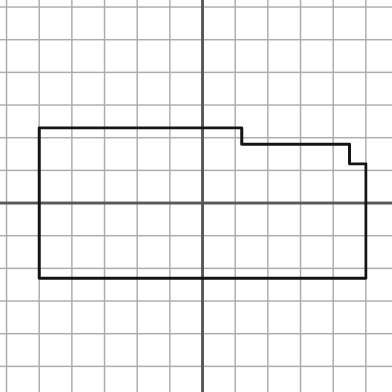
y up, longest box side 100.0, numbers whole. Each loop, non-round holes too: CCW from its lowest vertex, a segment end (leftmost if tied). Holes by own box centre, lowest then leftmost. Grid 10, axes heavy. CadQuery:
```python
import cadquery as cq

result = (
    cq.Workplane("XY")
    .moveTo(-50.0, -23.0)
    .lineTo(50.0, -23.0)
    .lineTo(50.0, 12.0)
    .lineTo(45.0, 12.0)
    .lineTo(45.0, 18.0)
    .lineTo(12.0, 18.0)
    .lineTo(12.0, 23.0)
    .lineTo(-50.0, 23.0)
    .close()
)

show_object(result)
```